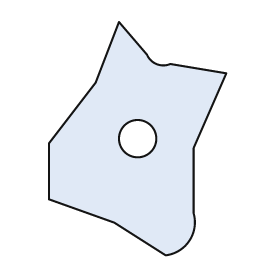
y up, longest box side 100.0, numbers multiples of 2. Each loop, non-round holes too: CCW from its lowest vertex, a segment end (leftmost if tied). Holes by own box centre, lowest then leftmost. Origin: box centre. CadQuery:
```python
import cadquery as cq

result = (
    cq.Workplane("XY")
    .moveTo(12.0, -50.0)
    .threePointArc((22.0, -44.0), (24.0, -32.0))
    .lineTo(24.0, -4.0)
    .lineTo(38.0, 28.0)
    .lineTo(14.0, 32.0)
    .threePointArc((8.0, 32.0), (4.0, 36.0))
    .lineTo(-8.0, 50.0)
    .lineTo(-18.0, 24.0)
    .lineTo(-38.0, -2.0)
    .lineTo(-38.0, -26.0)
    .lineTo(-10.0, -36.0)
    .close()
    .moveTo(0.0, 0.0)
    .circle(8.0)
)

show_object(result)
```